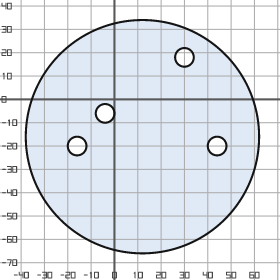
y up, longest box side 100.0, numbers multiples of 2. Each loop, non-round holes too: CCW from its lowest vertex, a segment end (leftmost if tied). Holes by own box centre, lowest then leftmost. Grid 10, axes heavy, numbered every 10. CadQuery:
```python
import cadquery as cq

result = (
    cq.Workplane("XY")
    .moveTo(12.0, -16.0)
    .circle(50.0)
    .moveTo(-16.0, -20.0)
    .circle(4.0)
    .moveTo(44.0, -20.0)
    .circle(4.0)
    .moveTo(-4.0, -6.0)
    .circle(4.0)
    .moveTo(30.0, 18.0)
    .circle(4.0)
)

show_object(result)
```